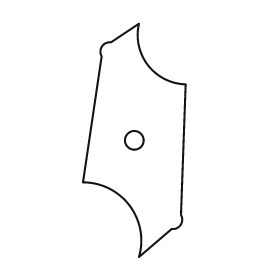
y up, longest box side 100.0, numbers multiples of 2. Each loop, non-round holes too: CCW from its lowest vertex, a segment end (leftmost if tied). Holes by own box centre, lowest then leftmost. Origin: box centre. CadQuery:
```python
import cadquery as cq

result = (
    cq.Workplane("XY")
    .moveTo(2.0, -50.0)
    .lineTo(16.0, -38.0)
    .threePointArc((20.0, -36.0), (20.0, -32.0))
    .lineTo(22.0, 24.0)
    .threePointArc((6.0, 32.0), (2.0, 50.0))
    .lineTo(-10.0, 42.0)
    .threePointArc((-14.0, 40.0), (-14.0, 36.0))
    .lineTo(-22.0, -18.0)
    .threePointArc((-2.0, -28.0), (2.0, -50.0))
    .close()
    .moveTo(0.0, 0.0)
    .circle(4.0)
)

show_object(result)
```